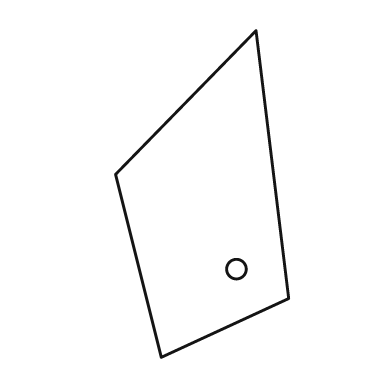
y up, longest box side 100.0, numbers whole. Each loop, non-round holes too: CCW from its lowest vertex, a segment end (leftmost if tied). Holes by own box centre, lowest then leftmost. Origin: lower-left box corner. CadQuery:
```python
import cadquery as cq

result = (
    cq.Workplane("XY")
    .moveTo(14.0, 0.0)
    .lineTo(53.0, 18.0)
    .lineTo(43.0, 100.0)
    .lineTo(0.0, 56.0)
    .close()
    .moveTo(37.0, 27.0)
    .circle(3.0)
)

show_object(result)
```